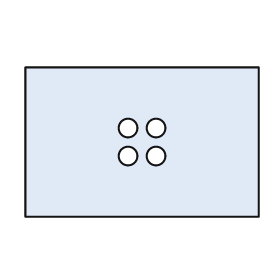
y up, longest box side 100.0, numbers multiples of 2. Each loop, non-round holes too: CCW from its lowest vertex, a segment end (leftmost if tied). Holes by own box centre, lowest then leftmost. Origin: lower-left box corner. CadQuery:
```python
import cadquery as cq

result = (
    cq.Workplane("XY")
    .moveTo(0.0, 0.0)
    .lineTo(100.0, 0.0)
    .lineTo(100.0, 64.0)
    .lineTo(0.0, 64.0)
    .close()
    .moveTo(44.0, 26.0)
    .circle(4.0)
    .moveTo(56.0, 26.0)
    .circle(4.0)
    .moveTo(44.0, 38.0)
    .circle(4.0)
    .moveTo(56.0, 38.0)
    .circle(4.0)
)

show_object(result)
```